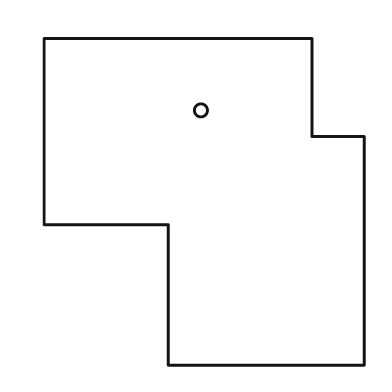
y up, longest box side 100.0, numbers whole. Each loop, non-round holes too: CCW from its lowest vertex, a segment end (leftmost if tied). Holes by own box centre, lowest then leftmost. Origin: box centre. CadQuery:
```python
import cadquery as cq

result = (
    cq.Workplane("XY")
    .moveTo(-11.0, -50.0)
    .lineTo(49.0, -50.0)
    .lineTo(49.0, 20.0)
    .lineTo(33.0, 20.0)
    .lineTo(33.0, 50.0)
    .lineTo(-49.0, 50.0)
    .lineTo(-49.0, -7.0)
    .lineTo(-11.0, -7.0)
    .close()
    .moveTo(-1.0, 28.0)
    .circle(2.0)
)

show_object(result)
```